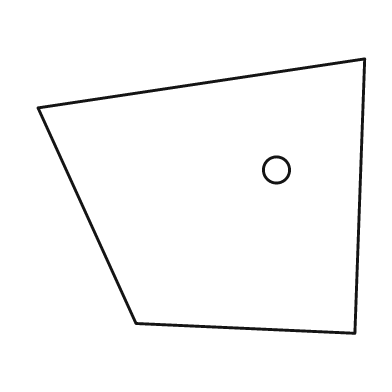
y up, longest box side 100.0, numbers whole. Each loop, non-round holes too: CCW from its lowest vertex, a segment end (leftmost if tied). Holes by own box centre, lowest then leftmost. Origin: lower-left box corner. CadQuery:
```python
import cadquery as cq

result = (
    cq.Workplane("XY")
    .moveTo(97.0, 0.0)
    .lineTo(100.0, 84.0)
    .lineTo(0.0, 69.0)
    .lineTo(30.0, 3.0)
    .close()
    .moveTo(73.0, 50.0)
    .circle(4.0)
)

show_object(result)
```